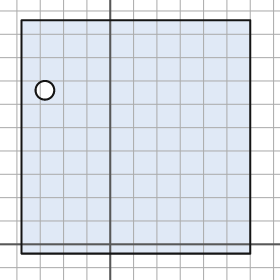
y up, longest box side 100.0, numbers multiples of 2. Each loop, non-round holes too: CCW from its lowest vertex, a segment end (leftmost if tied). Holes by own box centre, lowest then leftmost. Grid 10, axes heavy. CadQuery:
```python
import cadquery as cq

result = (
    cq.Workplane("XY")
    .moveTo(-38.0, -4.0)
    .lineTo(60.0, -4.0)
    .lineTo(60.0, 96.0)
    .lineTo(-38.0, 96.0)
    .close()
    .moveTo(-28.0, 66.0)
    .circle(4.0)
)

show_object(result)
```